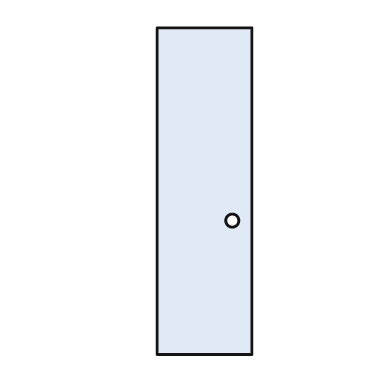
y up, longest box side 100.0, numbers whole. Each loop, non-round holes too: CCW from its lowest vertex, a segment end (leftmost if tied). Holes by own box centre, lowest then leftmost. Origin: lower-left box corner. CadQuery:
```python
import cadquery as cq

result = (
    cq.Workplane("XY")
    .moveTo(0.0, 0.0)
    .lineTo(29.0, 0.0)
    .lineTo(29.0, 100.0)
    .lineTo(0.0, 100.0)
    .close()
    .moveTo(23.0, 41.0)
    .circle(2.0)
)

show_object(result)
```